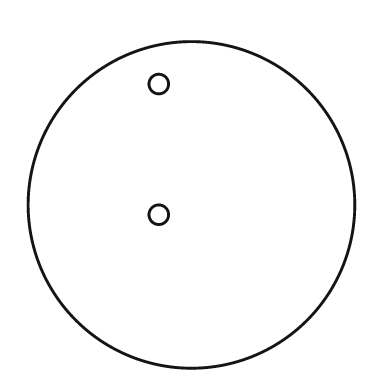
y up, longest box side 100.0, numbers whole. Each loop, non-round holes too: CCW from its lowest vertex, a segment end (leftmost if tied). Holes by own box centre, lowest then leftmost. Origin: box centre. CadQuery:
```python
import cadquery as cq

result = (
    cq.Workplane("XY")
    .moveTo(0.0, 0.0)
    .circle(50.0)
    .moveTo(-10.0, -3.0)
    .circle(3.0)
    .moveTo(-10.0, 37.0)
    .circle(3.0)
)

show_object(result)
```